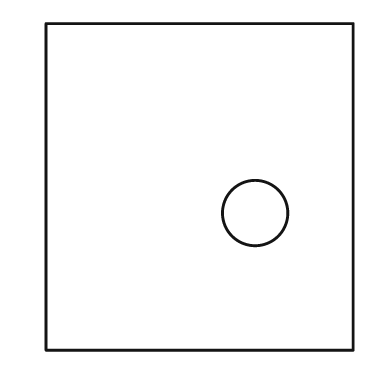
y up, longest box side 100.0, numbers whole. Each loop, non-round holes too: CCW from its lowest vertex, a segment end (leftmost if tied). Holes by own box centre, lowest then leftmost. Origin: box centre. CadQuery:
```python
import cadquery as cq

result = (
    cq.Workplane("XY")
    .moveTo(-47.0, -50.0)
    .lineTo(47.0, -50.0)
    .lineTo(47.0, 50.0)
    .lineTo(-47.0, 50.0)
    .close()
    .moveTo(17.0, -8.0)
    .circle(10.0)
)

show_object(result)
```